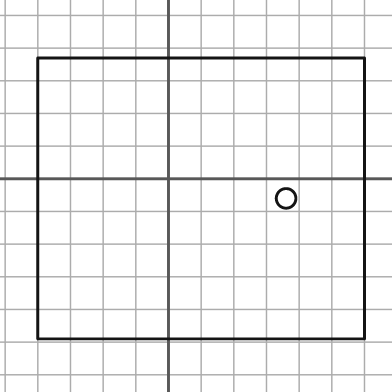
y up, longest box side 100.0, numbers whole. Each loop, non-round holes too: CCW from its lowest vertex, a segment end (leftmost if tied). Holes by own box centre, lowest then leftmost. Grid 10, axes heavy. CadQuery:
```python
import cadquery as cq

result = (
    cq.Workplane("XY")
    .moveTo(-40.0, -49.0)
    .lineTo(60.0, -49.0)
    .lineTo(60.0, 37.0)
    .lineTo(-40.0, 37.0)
    .close()
    .moveTo(36.0, -6.0)
    .circle(3.0)
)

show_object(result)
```